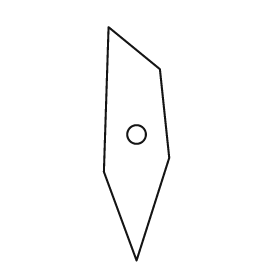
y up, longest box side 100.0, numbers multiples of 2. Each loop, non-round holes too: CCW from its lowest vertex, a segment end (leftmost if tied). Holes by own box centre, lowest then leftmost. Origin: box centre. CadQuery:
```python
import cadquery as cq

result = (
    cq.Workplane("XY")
    .moveTo(0.0, -50.0)
    .lineTo(14.0, -6.0)
    .lineTo(10.0, 32.0)
    .lineTo(-12.0, 50.0)
    .lineTo(-14.0, -12.0)
    .close()
    .moveTo(0.0, 4.0)
    .circle(4.0)
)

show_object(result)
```